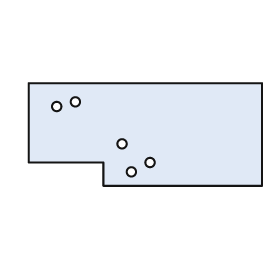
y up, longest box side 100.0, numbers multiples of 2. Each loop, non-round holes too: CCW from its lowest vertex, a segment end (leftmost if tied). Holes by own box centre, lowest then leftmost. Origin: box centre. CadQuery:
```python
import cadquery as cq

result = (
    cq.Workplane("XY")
    .moveTo(-18.0, -22.0)
    .lineTo(50.0, -22.0)
    .lineTo(50.0, 22.0)
    .lineTo(-50.0, 22.0)
    .lineTo(-50.0, -12.0)
    .lineTo(-18.0, -12.0)
    .close()
    .moveTo(-6.0, -16.0)
    .circle(2.0)
    .moveTo(2.0, -12.0)
    .circle(2.0)
    .moveTo(-10.0, -4.0)
    .circle(2.0)
    .moveTo(-38.0, 12.0)
    .circle(2.0)
    .moveTo(-30.0, 14.0)
    .circle(2.0)
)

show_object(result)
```